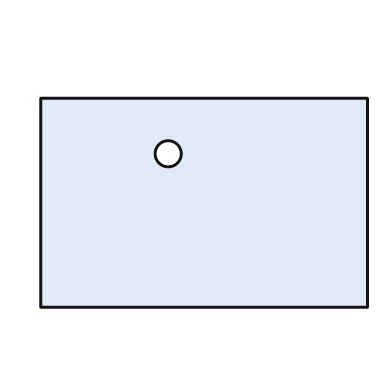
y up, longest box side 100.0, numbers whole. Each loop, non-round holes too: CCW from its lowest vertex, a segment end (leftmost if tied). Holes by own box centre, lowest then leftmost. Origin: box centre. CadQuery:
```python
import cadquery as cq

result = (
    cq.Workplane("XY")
    .moveTo(-50.0, -32.0)
    .lineTo(50.0, -32.0)
    .lineTo(50.0, 32.0)
    .lineTo(-50.0, 32.0)
    .close()
    .moveTo(-11.0, 15.0)
    .circle(4.0)
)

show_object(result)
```